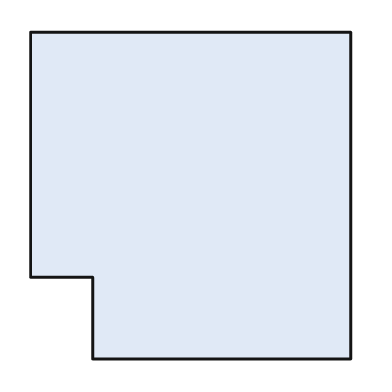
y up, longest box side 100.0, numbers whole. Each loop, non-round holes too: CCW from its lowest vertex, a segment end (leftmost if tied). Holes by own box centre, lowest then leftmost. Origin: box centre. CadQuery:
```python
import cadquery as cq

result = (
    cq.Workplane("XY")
    .moveTo(-30.0, -50.0)
    .lineTo(49.0, -50.0)
    .lineTo(49.0, 50.0)
    .lineTo(-49.0, 50.0)
    .lineTo(-49.0, -25.0)
    .lineTo(-30.0, -25.0)
    .close()
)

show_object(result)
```